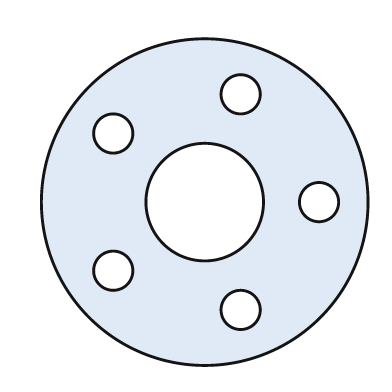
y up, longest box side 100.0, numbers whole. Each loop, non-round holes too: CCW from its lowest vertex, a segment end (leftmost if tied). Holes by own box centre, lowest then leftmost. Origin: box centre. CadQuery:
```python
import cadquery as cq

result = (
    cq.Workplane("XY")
    .moveTo(0.0, 0.0)
    .circle(50.0)
    .moveTo(11.0, -33.0)
    .circle(6.0)
    .moveTo(-28.0, -21.0)
    .circle(6.0)
    .moveTo(0.0, 0.0)
    .circle(18.0)
    .moveTo(35.0, 0.0)
    .circle(6.0)
    .moveTo(-28.0, 21.0)
    .circle(6.0)
    .moveTo(11.0, 33.0)
    .circle(6.0)
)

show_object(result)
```